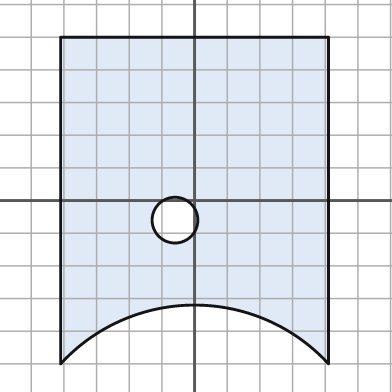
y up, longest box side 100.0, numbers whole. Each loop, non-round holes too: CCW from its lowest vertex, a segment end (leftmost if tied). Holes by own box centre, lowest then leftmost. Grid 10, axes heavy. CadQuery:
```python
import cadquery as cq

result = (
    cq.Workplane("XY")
    .moveTo(-41.0, -50.0)
    .threePointArc((0.0, -32.0), (41.0, -50.0))
    .lineTo(41.0, 50.0)
    .lineTo(-41.0, 50.0)
    .close()
    .moveTo(-6.0, -6.0)
    .circle(7.0)
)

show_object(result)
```